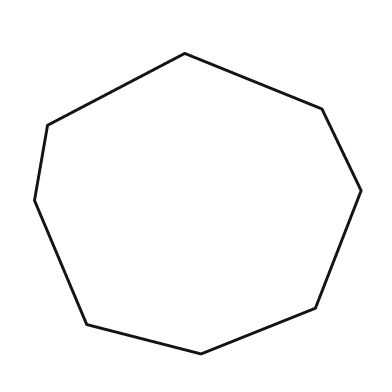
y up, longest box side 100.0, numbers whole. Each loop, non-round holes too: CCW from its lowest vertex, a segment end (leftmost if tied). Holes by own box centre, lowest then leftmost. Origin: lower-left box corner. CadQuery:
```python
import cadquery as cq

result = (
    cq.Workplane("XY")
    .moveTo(51.0, 0.0)
    .lineTo(86.0, 14.0)
    .lineTo(100.0, 50.0)
    .lineTo(88.0, 75.0)
    .lineTo(46.0, 92.0)
    .lineTo(4.0, 70.0)
    .lineTo(0.0, 47.0)
    .lineTo(16.0, 9.0)
    .close()
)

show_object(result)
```